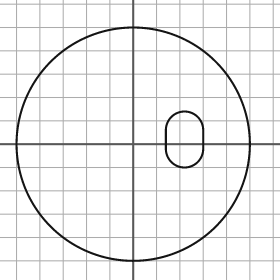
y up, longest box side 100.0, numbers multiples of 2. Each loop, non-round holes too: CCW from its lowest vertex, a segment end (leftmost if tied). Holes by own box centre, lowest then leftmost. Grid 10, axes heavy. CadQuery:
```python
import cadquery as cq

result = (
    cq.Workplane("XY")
    .moveTo(0.0, 0.0)
    .circle(50.0)
    .moveTo(14.0, -2.0)
    .threePointArc((22.0, -10.0), (30.0, -2.0))
    .lineTo(30.0, 6.0)
    .threePointArc((22.0, 14.0), (14.0, 6.0))
    .close()
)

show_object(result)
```